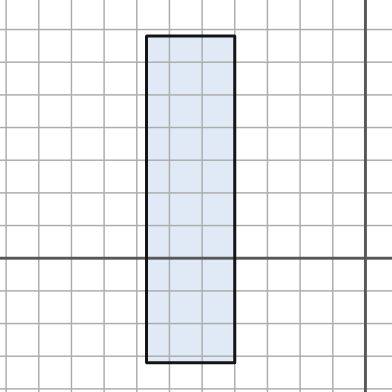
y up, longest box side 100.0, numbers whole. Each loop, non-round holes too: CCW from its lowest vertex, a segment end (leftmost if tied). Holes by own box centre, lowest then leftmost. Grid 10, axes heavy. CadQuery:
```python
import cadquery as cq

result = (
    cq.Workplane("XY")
    .moveTo(-67.0, -32.0)
    .lineTo(-40.0, -32.0)
    .lineTo(-40.0, 68.0)
    .lineTo(-67.0, 68.0)
    .close()
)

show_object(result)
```